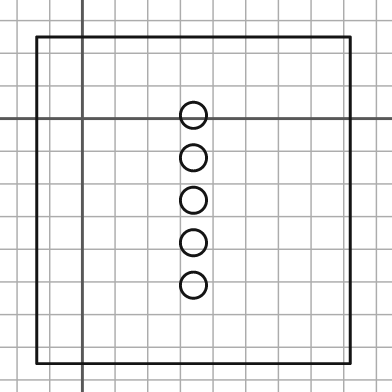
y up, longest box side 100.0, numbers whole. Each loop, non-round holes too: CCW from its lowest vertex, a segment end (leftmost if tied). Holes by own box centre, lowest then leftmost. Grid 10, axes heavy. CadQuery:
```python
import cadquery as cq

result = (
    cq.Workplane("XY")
    .moveTo(-14.0, -75.0)
    .lineTo(82.0, -75.0)
    .lineTo(82.0, 25.0)
    .lineTo(-14.0, 25.0)
    .close()
    .moveTo(34.0, -51.0)
    .circle(4.0)
    .moveTo(34.0, -38.0)
    .circle(4.0)
    .moveTo(34.0, -25.0)
    .circle(4.0)
    .moveTo(34.0, -12.0)
    .circle(4.0)
    .moveTo(34.0, 1.0)
    .circle(4.0)
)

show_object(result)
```